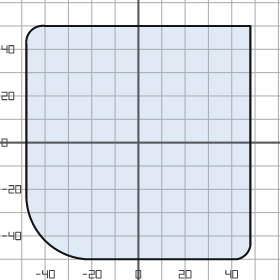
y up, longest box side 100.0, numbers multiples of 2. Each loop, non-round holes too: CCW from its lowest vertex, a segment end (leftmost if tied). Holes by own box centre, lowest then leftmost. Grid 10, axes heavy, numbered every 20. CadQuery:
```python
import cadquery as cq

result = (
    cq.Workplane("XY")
    .moveTo(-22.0, -50.0)
    .lineTo(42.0, -50.0)
    .threePointArc((46.0, -48.0), (48.0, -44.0))
    .lineTo(48.0, 50.0)
    .lineTo(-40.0, 50.0)
    .threePointArc((-46.0, 48.0), (-48.0, 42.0))
    .lineTo(-48.0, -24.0)
    .threePointArc((-40.0, -42.0), (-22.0, -50.0))
    .close()
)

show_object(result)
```